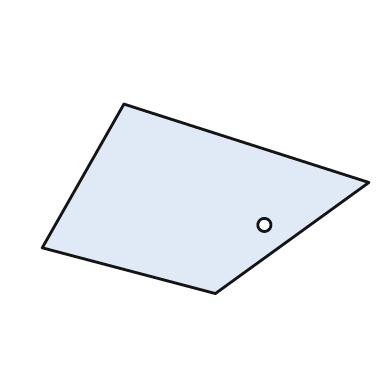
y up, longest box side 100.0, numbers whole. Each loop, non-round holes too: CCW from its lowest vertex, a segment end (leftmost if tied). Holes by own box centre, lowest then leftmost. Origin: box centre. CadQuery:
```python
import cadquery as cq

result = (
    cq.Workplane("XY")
    .moveTo(3.0, -29.0)
    .lineTo(50.0, 5.0)
    .lineTo(-25.0, 29.0)
    .lineTo(-50.0, -15.0)
    .close()
    .moveTo(18.0, -8.0)
    .circle(2.0)
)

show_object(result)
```